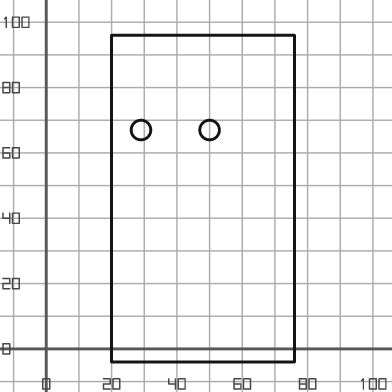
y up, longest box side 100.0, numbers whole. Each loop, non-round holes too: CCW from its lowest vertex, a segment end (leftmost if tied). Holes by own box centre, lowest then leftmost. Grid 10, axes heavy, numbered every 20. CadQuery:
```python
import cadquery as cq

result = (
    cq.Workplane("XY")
    .moveTo(20.0, -4.0)
    .lineTo(76.0, -4.0)
    .lineTo(76.0, 96.0)
    .lineTo(20.0, 96.0)
    .close()
    .moveTo(29.0, 67.0)
    .circle(3.0)
    .moveTo(50.0, 67.0)
    .circle(3.0)
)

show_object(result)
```